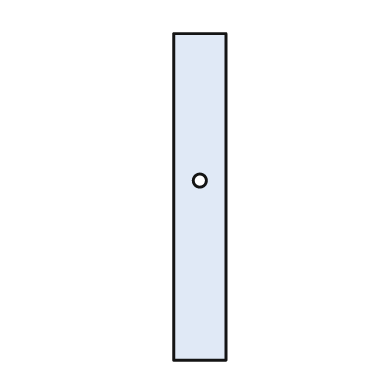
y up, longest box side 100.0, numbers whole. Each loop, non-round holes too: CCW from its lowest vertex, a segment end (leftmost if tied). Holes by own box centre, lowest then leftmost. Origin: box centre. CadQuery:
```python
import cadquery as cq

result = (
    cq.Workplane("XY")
    .moveTo(-8.0, -50.0)
    .lineTo(8.0, -50.0)
    .lineTo(8.0, 50.0)
    .lineTo(-8.0, 50.0)
    .close()
    .moveTo(0.0, 5.0)
    .circle(2.0)
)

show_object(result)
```